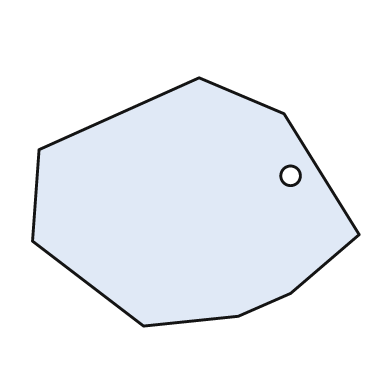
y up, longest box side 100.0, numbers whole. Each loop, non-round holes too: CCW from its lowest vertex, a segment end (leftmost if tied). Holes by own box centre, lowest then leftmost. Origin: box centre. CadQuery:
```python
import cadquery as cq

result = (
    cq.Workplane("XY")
    .moveTo(-16.0, -38.0)
    .lineTo(13.0, -35.0)
    .lineTo(29.0, -28.0)
    .lineTo(50.0, -10.0)
    .lineTo(27.0, 27.0)
    .lineTo(1.0, 38.0)
    .lineTo(-48.0, 16.0)
    .lineTo(-50.0, -12.0)
    .close()
    .moveTo(29.0, 8.0)
    .circle(3.0)
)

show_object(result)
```